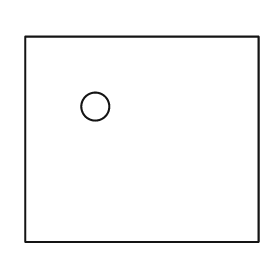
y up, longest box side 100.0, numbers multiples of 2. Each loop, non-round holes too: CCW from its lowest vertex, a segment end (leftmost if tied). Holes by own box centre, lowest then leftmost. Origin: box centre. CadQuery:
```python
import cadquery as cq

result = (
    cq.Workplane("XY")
    .moveTo(-50.0, -44.0)
    .lineTo(50.0, -44.0)
    .lineTo(50.0, 44.0)
    .lineTo(-50.0, 44.0)
    .close()
    .moveTo(-20.0, 14.0)
    .circle(6.0)
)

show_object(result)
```